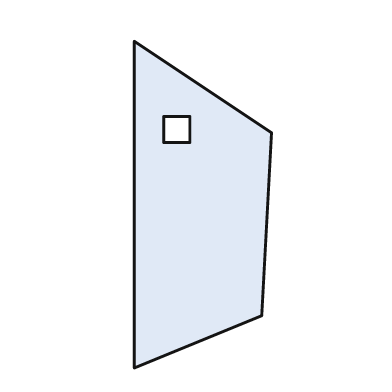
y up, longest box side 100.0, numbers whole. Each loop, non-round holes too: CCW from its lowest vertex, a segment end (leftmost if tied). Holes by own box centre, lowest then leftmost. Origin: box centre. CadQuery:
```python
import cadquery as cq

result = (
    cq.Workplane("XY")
    .moveTo(-21.0, -50.0)
    .lineTo(18.0, -34.0)
    .lineTo(21.0, 22.0)
    .lineTo(-21.0, 50.0)
    .close()
    .moveTo(-12.0, 19.0)
    .lineTo(-4.0, 19.0)
    .lineTo(-4.0, 27.0)
    .lineTo(-12.0, 27.0)
    .close()
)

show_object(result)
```